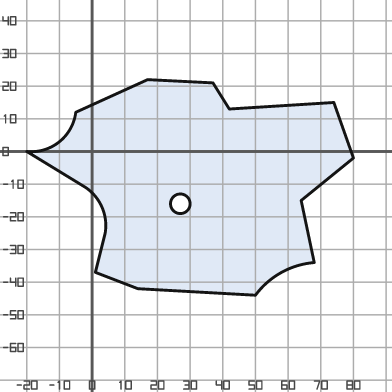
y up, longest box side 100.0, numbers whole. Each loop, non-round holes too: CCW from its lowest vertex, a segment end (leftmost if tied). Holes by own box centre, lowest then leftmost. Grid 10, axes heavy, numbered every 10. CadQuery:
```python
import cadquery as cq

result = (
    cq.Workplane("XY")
    .moveTo(50.0, -44.0)
    .threePointArc((58.0, -37.0), (68.0, -34.0))
    .lineTo(64.0, -15.0)
    .lineTo(80.0, -2.0)
    .lineTo(74.0, 15.0)
    .lineTo(42.0, 13.0)
    .lineTo(37.0, 21.0)
    .lineTo(17.0, 22.0)
    .lineTo(-5.0, 12.0)
    .threePointArc((-10.0, 3.0), (-20.0, 0.0))
    .lineTo(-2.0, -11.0)
    .threePointArc((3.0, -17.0), (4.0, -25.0))
    .lineTo(1.0, -37.0)
    .lineTo(14.0, -42.0)
    .close()
    .moveTo(27.0, -16.0)
    .circle(3.0)
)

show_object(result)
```